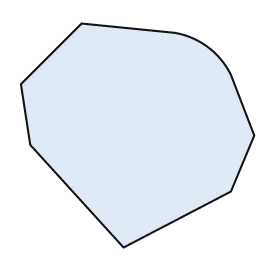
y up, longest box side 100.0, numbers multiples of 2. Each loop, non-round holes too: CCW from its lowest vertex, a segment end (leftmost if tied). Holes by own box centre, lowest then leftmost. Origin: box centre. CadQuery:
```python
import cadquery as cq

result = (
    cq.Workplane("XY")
    .moveTo(-6.0, -48.0)
    .lineTo(40.0, -24.0)
    .lineTo(50.0, 0.0)
    .lineTo(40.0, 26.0)
    .threePointArc((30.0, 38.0), (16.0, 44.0))
    .lineTo(-24.0, 48.0)
    .lineTo(-50.0, 22.0)
    .lineTo(-46.0, -4.0)
    .close()
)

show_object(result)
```